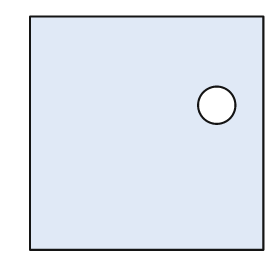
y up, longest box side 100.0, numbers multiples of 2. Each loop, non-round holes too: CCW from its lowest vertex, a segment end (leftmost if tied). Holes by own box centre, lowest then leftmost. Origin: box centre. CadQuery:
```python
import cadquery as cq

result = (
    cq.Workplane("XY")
    .moveTo(-50.0, -50.0)
    .lineTo(50.0, -50.0)
    .lineTo(50.0, 50.0)
    .lineTo(-50.0, 50.0)
    .close()
    .moveTo(30.0, 12.0)
    .circle(8.0)
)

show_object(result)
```